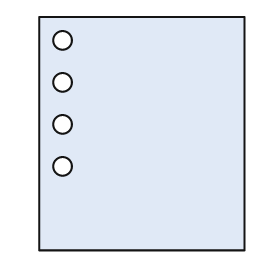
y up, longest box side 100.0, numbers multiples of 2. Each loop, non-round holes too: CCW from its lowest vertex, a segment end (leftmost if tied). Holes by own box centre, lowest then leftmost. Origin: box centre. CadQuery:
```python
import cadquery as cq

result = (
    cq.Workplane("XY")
    .moveTo(-44.0, -50.0)
    .lineTo(44.0, -50.0)
    .lineTo(44.0, 50.0)
    .lineTo(-44.0, 50.0)
    .close()
    .moveTo(-34.0, -14.0)
    .circle(4.0)
    .moveTo(-34.0, 4.0)
    .circle(4.0)
    .moveTo(-34.0, 22.0)
    .circle(4.0)
    .moveTo(-34.0, 40.0)
    .circle(4.0)
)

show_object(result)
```